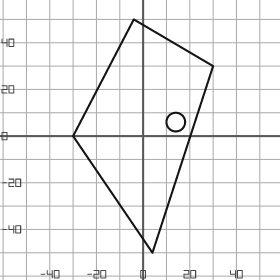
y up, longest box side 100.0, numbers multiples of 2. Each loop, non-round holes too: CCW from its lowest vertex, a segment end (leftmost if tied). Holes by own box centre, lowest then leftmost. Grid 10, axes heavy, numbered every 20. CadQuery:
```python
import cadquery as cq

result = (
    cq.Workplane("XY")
    .moveTo(4.0, -50.0)
    .lineTo(30.0, 30.0)
    .lineTo(-4.0, 50.0)
    .lineTo(-30.0, 0.0)
    .close()
    .moveTo(14.0, 6.0)
    .circle(4.0)
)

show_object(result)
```